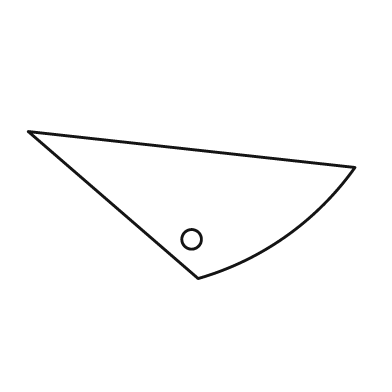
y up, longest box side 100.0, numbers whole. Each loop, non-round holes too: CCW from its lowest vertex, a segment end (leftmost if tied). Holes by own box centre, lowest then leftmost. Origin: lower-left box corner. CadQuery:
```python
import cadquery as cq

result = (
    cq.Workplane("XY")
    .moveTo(52.0, 0.0)
    .threePointArc((79.0, 13.0), (100.0, 34.0))
    .lineTo(0.0, 45.0)
    .close()
    .moveTo(50.0, 12.0)
    .circle(3.0)
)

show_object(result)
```